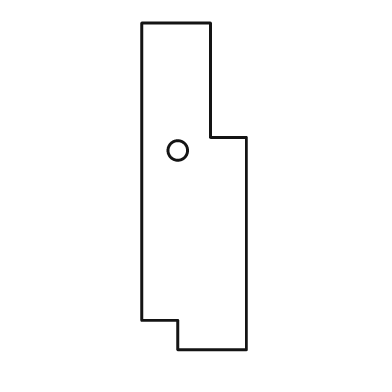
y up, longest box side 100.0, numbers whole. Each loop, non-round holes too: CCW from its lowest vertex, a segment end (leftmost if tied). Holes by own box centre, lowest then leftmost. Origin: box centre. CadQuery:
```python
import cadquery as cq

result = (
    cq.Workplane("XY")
    .moveTo(-5.0, -50.0)
    .lineTo(16.0, -50.0)
    .lineTo(16.0, 15.0)
    .lineTo(5.0, 15.0)
    .lineTo(5.0, 50.0)
    .lineTo(-16.0, 50.0)
    .lineTo(-16.0, -41.0)
    .lineTo(-5.0, -41.0)
    .close()
    .moveTo(-5.0, 11.0)
    .circle(3.0)
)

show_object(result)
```